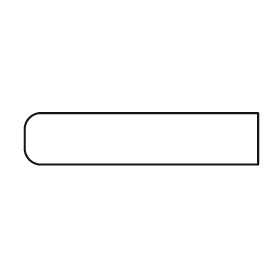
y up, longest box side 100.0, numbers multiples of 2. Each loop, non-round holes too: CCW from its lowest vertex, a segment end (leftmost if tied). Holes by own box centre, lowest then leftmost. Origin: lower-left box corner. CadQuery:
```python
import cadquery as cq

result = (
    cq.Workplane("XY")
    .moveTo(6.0, 0.0)
    .lineTo(100.0, 0.0)
    .lineTo(100.0, 22.0)
    .lineTo(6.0, 22.0)
    .threePointArc((2.0, 20.0), (0.0, 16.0))
    .lineTo(0.0, 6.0)
    .threePointArc((2.0, 2.0), (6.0, 0.0))
    .close()
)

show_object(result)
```